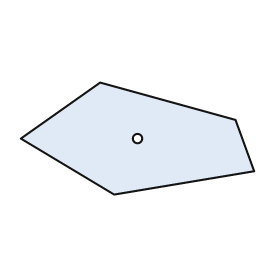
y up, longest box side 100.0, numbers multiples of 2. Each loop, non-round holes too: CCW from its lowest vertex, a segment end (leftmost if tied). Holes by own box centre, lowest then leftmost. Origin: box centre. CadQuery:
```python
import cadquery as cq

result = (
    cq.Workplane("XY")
    .moveTo(-10.0, -24.0)
    .lineTo(50.0, -14.0)
    .lineTo(42.0, 8.0)
    .lineTo(-16.0, 24.0)
    .lineTo(-50.0, 0.0)
    .close()
    .moveTo(0.0, 0.0)
    .circle(2.0)
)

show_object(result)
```